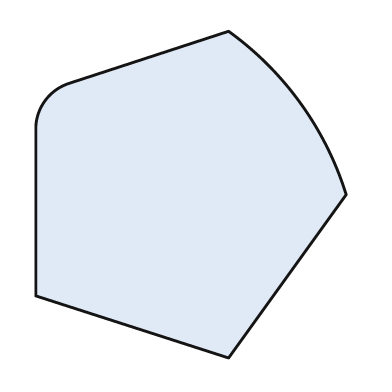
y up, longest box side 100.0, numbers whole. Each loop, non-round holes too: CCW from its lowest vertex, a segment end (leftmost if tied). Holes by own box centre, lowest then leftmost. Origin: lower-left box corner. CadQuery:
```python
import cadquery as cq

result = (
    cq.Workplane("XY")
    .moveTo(59.0, 0.0)
    .lineTo(95.0, 50.0)
    .threePointArc((81.0, 78.0), (59.0, 100.0))
    .lineTo(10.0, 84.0)
    .threePointArc((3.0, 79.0), (0.0, 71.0))
    .lineTo(0.0, 19.0)
    .close()
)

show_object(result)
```